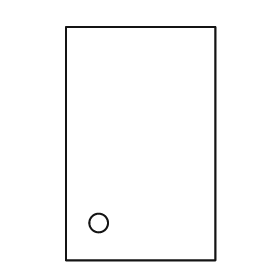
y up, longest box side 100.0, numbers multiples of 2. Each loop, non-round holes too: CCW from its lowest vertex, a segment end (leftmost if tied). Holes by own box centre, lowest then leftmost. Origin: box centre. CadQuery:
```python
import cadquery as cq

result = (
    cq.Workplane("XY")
    .moveTo(-32.0, -50.0)
    .lineTo(32.0, -50.0)
    .lineTo(32.0, 50.0)
    .lineTo(-32.0, 50.0)
    .close()
    .moveTo(-18.0, -34.0)
    .circle(4.0)
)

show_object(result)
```